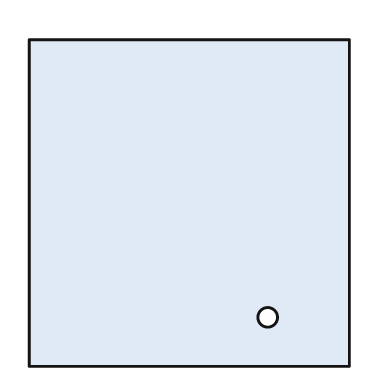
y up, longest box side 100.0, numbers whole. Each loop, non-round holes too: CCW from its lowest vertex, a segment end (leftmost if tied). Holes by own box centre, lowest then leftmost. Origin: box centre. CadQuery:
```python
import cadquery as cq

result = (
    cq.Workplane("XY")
    .moveTo(-49.0, -50.0)
    .lineTo(49.0, -50.0)
    .lineTo(49.0, 50.0)
    .lineTo(-49.0, 50.0)
    .close()
    .moveTo(24.0, -35.0)
    .circle(3.0)
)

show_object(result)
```